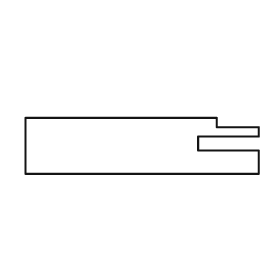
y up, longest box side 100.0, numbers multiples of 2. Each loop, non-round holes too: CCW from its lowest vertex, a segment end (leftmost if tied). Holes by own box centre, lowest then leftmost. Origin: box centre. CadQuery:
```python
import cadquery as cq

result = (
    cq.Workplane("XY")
    .moveTo(-50.0, -12.0)
    .lineTo(50.0, -12.0)
    .lineTo(50.0, -2.0)
    .lineTo(24.0, -2.0)
    .lineTo(24.0, 4.0)
    .lineTo(50.0, 4.0)
    .lineTo(50.0, 8.0)
    .lineTo(32.0, 8.0)
    .lineTo(32.0, 12.0)
    .lineTo(-50.0, 12.0)
    .close()
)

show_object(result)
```